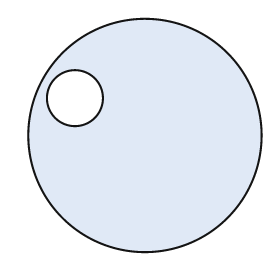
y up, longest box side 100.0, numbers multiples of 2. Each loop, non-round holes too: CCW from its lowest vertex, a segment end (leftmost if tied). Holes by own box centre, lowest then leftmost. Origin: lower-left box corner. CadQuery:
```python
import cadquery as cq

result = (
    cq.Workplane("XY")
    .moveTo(50.0, 50.0)
    .circle(50.0)
    .moveTo(20.0, 66.0)
    .circle(12.0)
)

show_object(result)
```